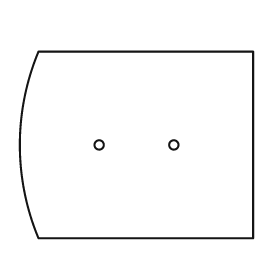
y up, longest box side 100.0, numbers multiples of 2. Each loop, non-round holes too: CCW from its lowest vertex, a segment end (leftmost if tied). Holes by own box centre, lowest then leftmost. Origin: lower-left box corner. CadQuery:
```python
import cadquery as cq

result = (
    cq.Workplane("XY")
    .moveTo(8.0, 0.0)
    .lineTo(100.0, 0.0)
    .lineTo(100.0, 80.0)
    .lineTo(8.0, 80.0)
    .threePointArc((0.0, 40.0), (8.0, 0.0))
    .close()
    .moveTo(34.0, 40.0)
    .circle(2.0)
    .moveTo(66.0, 40.0)
    .circle(2.0)
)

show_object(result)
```